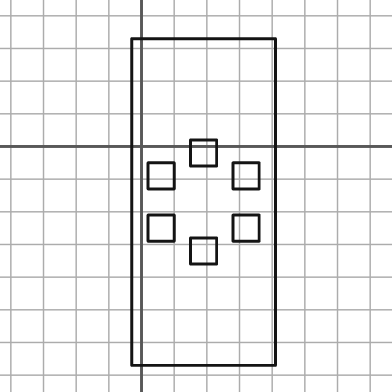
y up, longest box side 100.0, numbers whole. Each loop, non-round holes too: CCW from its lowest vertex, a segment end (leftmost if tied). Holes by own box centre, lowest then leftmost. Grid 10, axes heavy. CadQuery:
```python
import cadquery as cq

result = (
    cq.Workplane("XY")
    .moveTo(-3.0, -67.0)
    .lineTo(41.0, -67.0)
    .lineTo(41.0, 33.0)
    .lineTo(-3.0, 33.0)
    .close()
    .moveTo(15.0, -36.0)
    .lineTo(23.0, -36.0)
    .lineTo(23.0, -28.0)
    .lineTo(15.0, -28.0)
    .close()
    .moveTo(2.0, -29.0)
    .lineTo(10.0, -29.0)
    .lineTo(10.0, -21.0)
    .lineTo(2.0, -21.0)
    .close()
    .moveTo(28.0, -29.0)
    .lineTo(36.0, -29.0)
    .lineTo(36.0, -21.0)
    .lineTo(28.0, -21.0)
    .close()
    .moveTo(2.0, -13.0)
    .lineTo(10.0, -13.0)
    .lineTo(10.0, -5.0)
    .lineTo(2.0, -5.0)
    .close()
    .moveTo(28.0, -13.0)
    .lineTo(36.0, -13.0)
    .lineTo(36.0, -5.0)
    .lineTo(28.0, -5.0)
    .close()
    .moveTo(15.0, -6.0)
    .lineTo(23.0, -6.0)
    .lineTo(23.0, 2.0)
    .lineTo(15.0, 2.0)
    .close()
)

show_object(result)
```